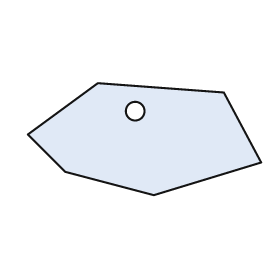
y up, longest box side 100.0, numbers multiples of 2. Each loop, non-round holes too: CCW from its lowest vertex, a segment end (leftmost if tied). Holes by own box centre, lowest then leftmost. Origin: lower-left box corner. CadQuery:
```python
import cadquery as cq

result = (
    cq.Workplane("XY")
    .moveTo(54.0, 0.0)
    .lineTo(100.0, 14.0)
    .lineTo(84.0, 44.0)
    .lineTo(30.0, 48.0)
    .lineTo(0.0, 26.0)
    .lineTo(16.0, 10.0)
    .close()
    .moveTo(46.0, 36.0)
    .circle(4.0)
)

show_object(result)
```